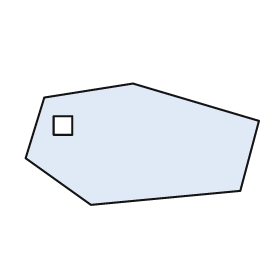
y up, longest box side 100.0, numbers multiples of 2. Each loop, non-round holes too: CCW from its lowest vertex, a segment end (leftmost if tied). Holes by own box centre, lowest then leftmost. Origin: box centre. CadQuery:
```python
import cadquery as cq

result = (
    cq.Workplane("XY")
    .moveTo(-22.0, -26.0)
    .lineTo(42.0, -20.0)
    .lineTo(50.0, 10.0)
    .lineTo(-4.0, 26.0)
    .lineTo(-42.0, 20.0)
    .lineTo(-50.0, -6.0)
    .close()
    .moveTo(-38.0, 4.0)
    .lineTo(-30.0, 4.0)
    .lineTo(-30.0, 12.0)
    .lineTo(-38.0, 12.0)
    .close()
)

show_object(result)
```